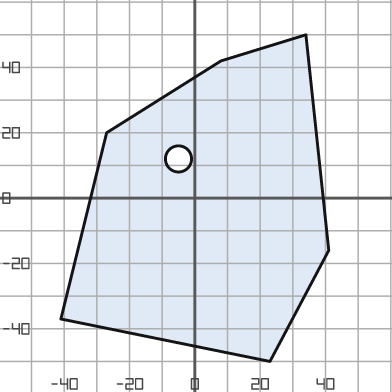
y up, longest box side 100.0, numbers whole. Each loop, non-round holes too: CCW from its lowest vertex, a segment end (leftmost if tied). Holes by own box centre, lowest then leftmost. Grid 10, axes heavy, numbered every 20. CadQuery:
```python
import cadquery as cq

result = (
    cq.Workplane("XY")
    .moveTo(23.0, -50.0)
    .lineTo(41.0, -16.0)
    .lineTo(34.0, 50.0)
    .lineTo(8.0, 42.0)
    .lineTo(-27.0, 20.0)
    .lineTo(-41.0, -37.0)
    .close()
    .moveTo(-5.0, 12.0)
    .circle(4.0)
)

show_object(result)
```